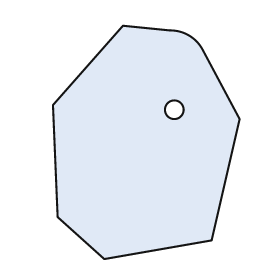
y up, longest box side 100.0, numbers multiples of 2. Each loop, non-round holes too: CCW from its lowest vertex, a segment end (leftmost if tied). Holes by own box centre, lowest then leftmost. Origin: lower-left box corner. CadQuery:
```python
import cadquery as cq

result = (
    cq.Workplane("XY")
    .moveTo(22.0, 0.0)
    .lineTo(68.0, 8.0)
    .lineTo(80.0, 60.0)
    .lineTo(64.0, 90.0)
    .threePointArc((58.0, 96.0), (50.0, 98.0))
    .lineTo(30.0, 100.0)
    .lineTo(0.0, 66.0)
    .lineTo(2.0, 18.0)
    .close()
    .moveTo(52.0, 64.0)
    .circle(4.0)
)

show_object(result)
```